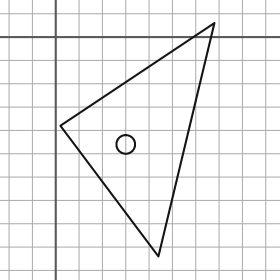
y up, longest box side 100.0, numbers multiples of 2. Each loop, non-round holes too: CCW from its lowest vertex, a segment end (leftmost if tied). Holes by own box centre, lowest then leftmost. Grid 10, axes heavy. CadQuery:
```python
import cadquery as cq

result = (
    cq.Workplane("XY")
    .moveTo(44.0, -94.0)
    .lineTo(68.0, 6.0)
    .lineTo(2.0, -38.0)
    .close()
    .moveTo(30.0, -46.0)
    .circle(4.0)
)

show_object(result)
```